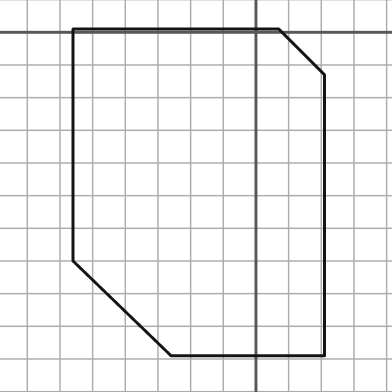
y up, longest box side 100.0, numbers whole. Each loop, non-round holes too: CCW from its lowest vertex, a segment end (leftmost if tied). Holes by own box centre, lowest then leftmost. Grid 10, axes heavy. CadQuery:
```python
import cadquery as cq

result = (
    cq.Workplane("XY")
    .moveTo(-26.0, -99.0)
    .lineTo(21.0, -99.0)
    .lineTo(21.0, -13.0)
    .lineTo(7.0, 1.0)
    .lineTo(-56.0, 1.0)
    .lineTo(-56.0, -70.0)
    .close()
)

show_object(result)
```